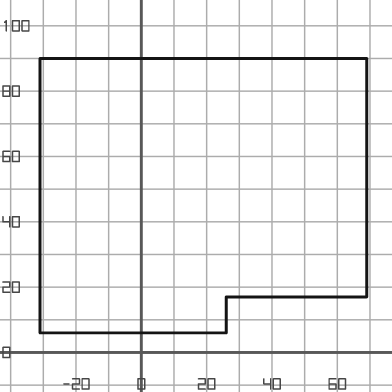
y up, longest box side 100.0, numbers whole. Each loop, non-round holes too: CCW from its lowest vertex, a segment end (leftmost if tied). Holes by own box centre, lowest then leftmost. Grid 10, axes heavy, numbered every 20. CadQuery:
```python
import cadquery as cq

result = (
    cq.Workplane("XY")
    .moveTo(-31.0, 6.0)
    .lineTo(26.0, 6.0)
    .lineTo(26.0, 17.0)
    .lineTo(69.0, 17.0)
    .lineTo(69.0, 90.0)
    .lineTo(-31.0, 90.0)
    .close()
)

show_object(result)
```